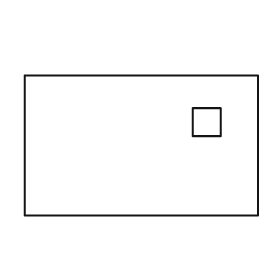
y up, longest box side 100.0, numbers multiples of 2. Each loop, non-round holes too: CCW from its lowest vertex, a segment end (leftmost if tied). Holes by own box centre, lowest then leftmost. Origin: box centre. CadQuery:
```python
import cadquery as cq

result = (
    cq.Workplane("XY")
    .moveTo(-50.0, -30.0)
    .lineTo(50.0, -30.0)
    .lineTo(50.0, 30.0)
    .lineTo(-50.0, 30.0)
    .close()
    .moveTo(22.0, 4.0)
    .lineTo(34.0, 4.0)
    .lineTo(34.0, 16.0)
    .lineTo(22.0, 16.0)
    .close()
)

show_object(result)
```